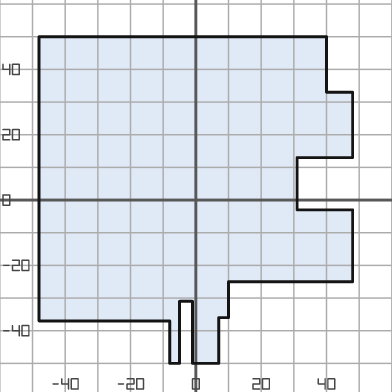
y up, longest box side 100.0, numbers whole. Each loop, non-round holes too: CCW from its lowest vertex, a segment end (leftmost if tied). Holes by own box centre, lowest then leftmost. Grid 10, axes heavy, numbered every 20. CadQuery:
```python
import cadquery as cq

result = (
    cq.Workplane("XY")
    .moveTo(-8.0, -50.0)
    .lineTo(-5.0, -50.0)
    .lineTo(-5.0, -31.0)
    .lineTo(-1.0, -31.0)
    .lineTo(-1.0, -50.0)
    .lineTo(7.0, -50.0)
    .lineTo(7.0, -36.0)
    .lineTo(10.0, -36.0)
    .lineTo(10.0, -25.0)
    .lineTo(48.0, -25.0)
    .lineTo(48.0, -3.0)
    .lineTo(31.0, -3.0)
    .lineTo(31.0, 13.0)
    .lineTo(48.0, 13.0)
    .lineTo(48.0, 33.0)
    .lineTo(40.0, 33.0)
    .lineTo(40.0, 50.0)
    .lineTo(-48.0, 50.0)
    .lineTo(-48.0, -37.0)
    .lineTo(-8.0, -37.0)
    .close()
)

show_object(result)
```